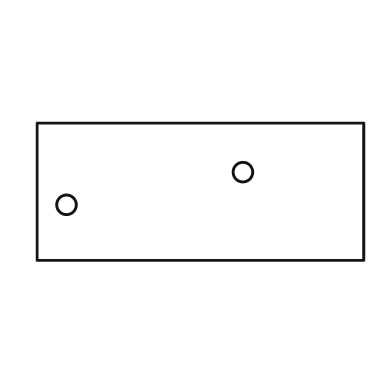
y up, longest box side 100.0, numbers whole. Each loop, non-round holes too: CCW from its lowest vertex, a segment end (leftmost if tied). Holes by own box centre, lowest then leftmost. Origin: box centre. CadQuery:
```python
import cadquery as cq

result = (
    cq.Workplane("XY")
    .moveTo(-50.0, -21.0)
    .lineTo(50.0, -21.0)
    .lineTo(50.0, 21.0)
    .lineTo(-50.0, 21.0)
    .close()
    .moveTo(-41.0, -4.0)
    .circle(3.0)
    .moveTo(13.0, 6.0)
    .circle(3.0)
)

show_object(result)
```